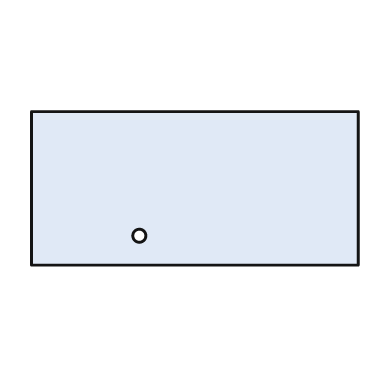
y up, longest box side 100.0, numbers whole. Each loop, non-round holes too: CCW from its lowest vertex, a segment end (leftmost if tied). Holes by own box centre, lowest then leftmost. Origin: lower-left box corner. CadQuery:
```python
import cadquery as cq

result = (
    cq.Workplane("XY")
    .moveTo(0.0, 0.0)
    .lineTo(100.0, 0.0)
    .lineTo(100.0, 47.0)
    .lineTo(0.0, 47.0)
    .close()
    .moveTo(33.0, 9.0)
    .circle(2.0)
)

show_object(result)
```